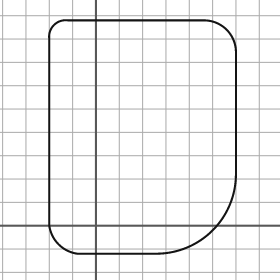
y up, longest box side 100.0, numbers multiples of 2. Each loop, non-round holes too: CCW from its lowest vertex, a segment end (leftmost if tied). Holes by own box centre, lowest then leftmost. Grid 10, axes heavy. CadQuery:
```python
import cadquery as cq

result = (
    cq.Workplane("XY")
    .moveTo(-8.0, -12.0)
    .lineTo(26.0, -12.0)
    .threePointArc((50.0, -2.0), (60.0, 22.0))
    .lineTo(60.0, 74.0)
    .threePointArc((56.0, 84.0), (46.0, 88.0))
    .lineTo(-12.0, 88.0)
    .threePointArc((-18.0, 86.0), (-20.0, 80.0))
    .lineTo(-20.0, 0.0)
    .threePointArc((-16.0, -8.0), (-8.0, -12.0))
    .close()
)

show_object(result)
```